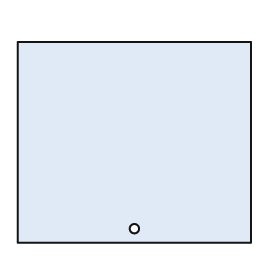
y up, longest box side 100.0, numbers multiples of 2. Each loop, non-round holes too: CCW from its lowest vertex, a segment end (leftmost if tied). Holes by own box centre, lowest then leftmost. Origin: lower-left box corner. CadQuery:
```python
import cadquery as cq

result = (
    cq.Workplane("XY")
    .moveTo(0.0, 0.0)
    .lineTo(100.0, 0.0)
    .lineTo(100.0, 86.0)
    .lineTo(0.0, 86.0)
    .close()
    .moveTo(50.0, 6.0)
    .circle(2.0)
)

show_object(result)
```